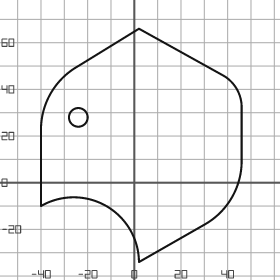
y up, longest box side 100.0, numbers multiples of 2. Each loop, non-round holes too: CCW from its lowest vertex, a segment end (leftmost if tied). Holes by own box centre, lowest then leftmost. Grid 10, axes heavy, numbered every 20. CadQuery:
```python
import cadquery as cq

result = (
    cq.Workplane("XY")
    .moveTo(2.0, -34.0)
    .lineTo(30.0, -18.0)
    .threePointArc((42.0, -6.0), (46.0, 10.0))
    .lineTo(46.0, 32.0)
    .threePointArc((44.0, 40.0), (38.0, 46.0))
    .lineTo(2.0, 66.0)
    .lineTo(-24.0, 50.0)
    .threePointArc((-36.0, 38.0), (-40.0, 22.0))
    .lineTo(-40.0, -10.0)
    .threePointArc((-12.0, -10.0), (2.0, -34.0))
    .close()
    .moveTo(-24.0, 28.0)
    .circle(4.0)
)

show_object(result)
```